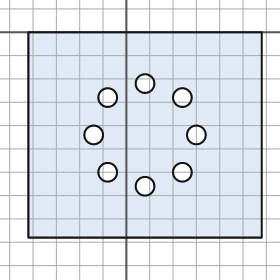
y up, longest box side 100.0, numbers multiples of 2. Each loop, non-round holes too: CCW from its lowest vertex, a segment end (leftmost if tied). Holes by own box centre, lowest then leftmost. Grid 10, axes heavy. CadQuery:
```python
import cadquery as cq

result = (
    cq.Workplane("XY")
    .moveTo(-42.0, -88.0)
    .lineTo(58.0, -88.0)
    .lineTo(58.0, 0.0)
    .lineTo(-42.0, 0.0)
    .close()
    .moveTo(8.0, -66.0)
    .circle(4.0)
    .moveTo(-8.0, -60.0)
    .circle(4.0)
    .moveTo(24.0, -60.0)
    .circle(4.0)
    .moveTo(-14.0, -44.0)
    .circle(4.0)
    .moveTo(30.0, -44.0)
    .circle(4.0)
    .moveTo(-8.0, -28.0)
    .circle(4.0)
    .moveTo(24.0, -28.0)
    .circle(4.0)
    .moveTo(8.0, -22.0)
    .circle(4.0)
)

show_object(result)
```